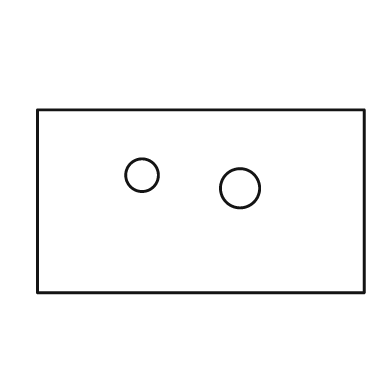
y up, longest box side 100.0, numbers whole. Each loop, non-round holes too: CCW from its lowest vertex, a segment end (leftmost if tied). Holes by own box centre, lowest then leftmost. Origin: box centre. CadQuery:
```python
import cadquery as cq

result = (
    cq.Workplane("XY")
    .moveTo(-50.0, -28.0)
    .lineTo(50.0, -28.0)
    .lineTo(50.0, 28.0)
    .lineTo(-50.0, 28.0)
    .close()
    .moveTo(12.0, 4.0)
    .circle(6.0)
    .moveTo(-18.0, 8.0)
    .circle(5.0)
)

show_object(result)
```